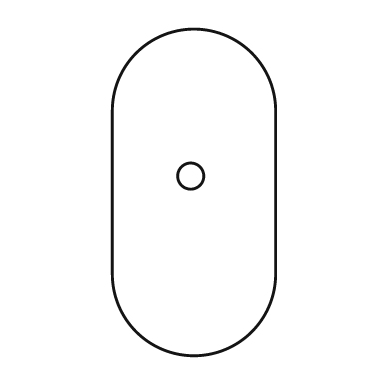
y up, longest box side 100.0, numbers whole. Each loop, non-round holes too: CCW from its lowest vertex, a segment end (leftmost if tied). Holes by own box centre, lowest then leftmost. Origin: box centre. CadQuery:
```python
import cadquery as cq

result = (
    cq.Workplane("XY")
    .moveTo(-25.0, -25.0)
    .threePointArc((0.0, -50.0), (25.0, -25.0))
    .lineTo(25.0, 25.0)
    .threePointArc((0.0, 50.0), (-25.0, 25.0))
    .close()
    .moveTo(-1.0, 5.0)
    .circle(4.0)
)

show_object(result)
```